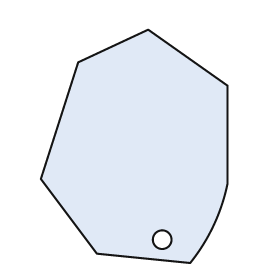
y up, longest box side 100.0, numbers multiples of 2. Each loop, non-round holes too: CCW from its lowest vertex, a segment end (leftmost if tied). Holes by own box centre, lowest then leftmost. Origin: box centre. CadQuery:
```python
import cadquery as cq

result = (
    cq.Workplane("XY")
    .moveTo(24.0, -50.0)
    .threePointArc((34.0, -34.0), (40.0, -16.0))
    .lineTo(40.0, 26.0)
    .lineTo(6.0, 50.0)
    .lineTo(-24.0, 36.0)
    .lineTo(-40.0, -14.0)
    .lineTo(-16.0, -46.0)
    .close()
    .moveTo(12.0, -40.0)
    .circle(4.0)
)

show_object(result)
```